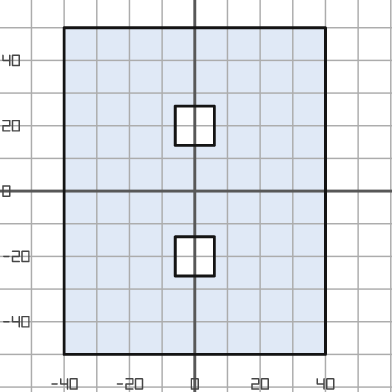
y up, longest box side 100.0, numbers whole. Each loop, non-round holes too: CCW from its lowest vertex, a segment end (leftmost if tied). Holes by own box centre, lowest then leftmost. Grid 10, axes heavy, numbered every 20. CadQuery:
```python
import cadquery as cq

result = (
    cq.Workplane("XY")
    .moveTo(-40.0, -50.0)
    .lineTo(40.0, -50.0)
    .lineTo(40.0, 50.0)
    .lineTo(-40.0, 50.0)
    .close()
    .moveTo(-6.0, -26.0)
    .lineTo(6.0, -26.0)
    .lineTo(6.0, -14.0)
    .lineTo(-6.0, -14.0)
    .close()
    .moveTo(-6.0, 14.0)
    .lineTo(6.0, 14.0)
    .lineTo(6.0, 26.0)
    .lineTo(-6.0, 26.0)
    .close()
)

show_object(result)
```